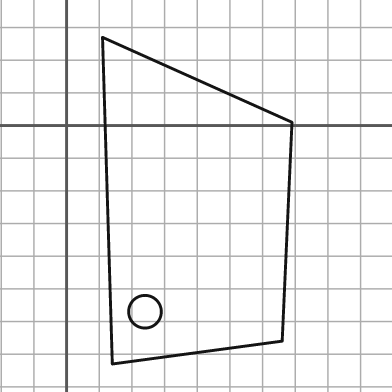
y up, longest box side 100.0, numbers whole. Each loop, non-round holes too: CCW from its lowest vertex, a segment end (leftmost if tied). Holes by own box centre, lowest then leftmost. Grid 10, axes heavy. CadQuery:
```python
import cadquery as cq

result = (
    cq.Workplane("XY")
    .moveTo(14.0, -73.0)
    .lineTo(66.0, -66.0)
    .lineTo(69.0, 1.0)
    .lineTo(11.0, 27.0)
    .close()
    .moveTo(24.0, -57.0)
    .circle(5.0)
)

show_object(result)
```